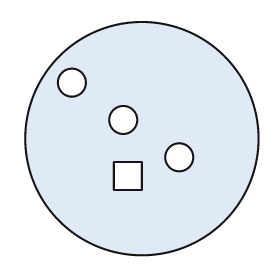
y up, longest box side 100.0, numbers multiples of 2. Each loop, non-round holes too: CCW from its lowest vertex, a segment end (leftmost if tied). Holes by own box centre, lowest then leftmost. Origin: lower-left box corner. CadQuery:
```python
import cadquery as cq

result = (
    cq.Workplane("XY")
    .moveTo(50.0, 50.0)
    .circle(50.0)
    .moveTo(38.0, 28.0)
    .lineTo(50.0, 28.0)
    .lineTo(50.0, 40.0)
    .lineTo(38.0, 40.0)
    .close()
    .moveTo(66.0, 42.0)
    .circle(6.0)
    .moveTo(42.0, 58.0)
    .circle(6.0)
    .moveTo(20.0, 74.0)
    .circle(6.0)
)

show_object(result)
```